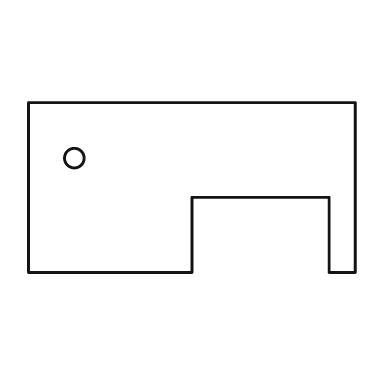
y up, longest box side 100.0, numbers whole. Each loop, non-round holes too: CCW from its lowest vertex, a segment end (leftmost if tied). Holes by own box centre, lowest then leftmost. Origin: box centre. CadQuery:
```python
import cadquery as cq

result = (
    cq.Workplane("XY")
    .moveTo(-50.0, -26.0)
    .lineTo(0.0, -26.0)
    .lineTo(0.0, -3.0)
    .lineTo(42.0, -3.0)
    .lineTo(42.0, -26.0)
    .lineTo(50.0, -26.0)
    .lineTo(50.0, 26.0)
    .lineTo(-50.0, 26.0)
    .close()
    .moveTo(-36.0, 9.0)
    .circle(3.0)
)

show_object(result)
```